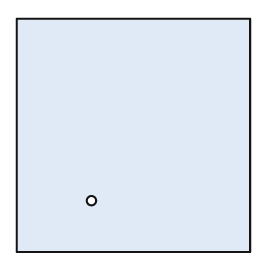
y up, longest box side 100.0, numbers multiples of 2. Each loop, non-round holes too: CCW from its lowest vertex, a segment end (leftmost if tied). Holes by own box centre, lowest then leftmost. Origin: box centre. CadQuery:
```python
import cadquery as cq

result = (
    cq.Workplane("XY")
    .moveTo(-50.0, -50.0)
    .lineTo(50.0, -50.0)
    .lineTo(50.0, 50.0)
    .lineTo(-50.0, 50.0)
    .close()
    .moveTo(-18.0, -28.0)
    .circle(2.0)
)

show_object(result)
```